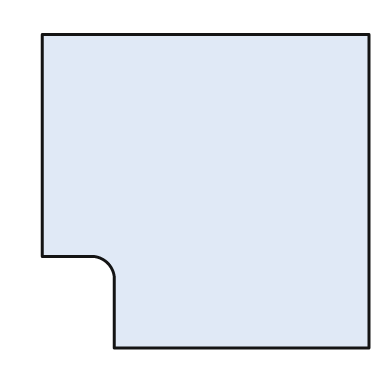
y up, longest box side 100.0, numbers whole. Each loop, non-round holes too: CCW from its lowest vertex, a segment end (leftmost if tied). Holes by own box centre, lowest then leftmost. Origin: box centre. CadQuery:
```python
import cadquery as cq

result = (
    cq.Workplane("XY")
    .moveTo(-28.0, -48.0)
    .lineTo(50.0, -48.0)
    .lineTo(50.0, 48.0)
    .lineTo(-50.0, 48.0)
    .lineTo(-50.0, -20.0)
    .lineTo(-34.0, -20.0)
    .threePointArc((-30.0, -22.0), (-28.0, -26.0))
    .close()
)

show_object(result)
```